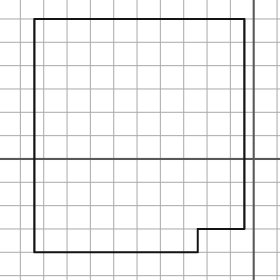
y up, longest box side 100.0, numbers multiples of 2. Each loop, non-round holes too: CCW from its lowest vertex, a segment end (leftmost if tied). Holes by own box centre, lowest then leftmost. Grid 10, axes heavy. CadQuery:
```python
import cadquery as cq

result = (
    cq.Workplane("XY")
    .moveTo(-94.0, -40.0)
    .lineTo(-24.0, -40.0)
    .lineTo(-24.0, -30.0)
    .lineTo(-4.0, -30.0)
    .lineTo(-4.0, 60.0)
    .lineTo(-94.0, 60.0)
    .close()
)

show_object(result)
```